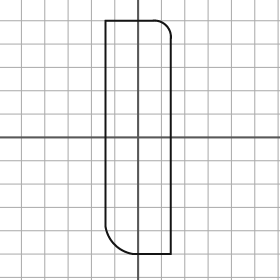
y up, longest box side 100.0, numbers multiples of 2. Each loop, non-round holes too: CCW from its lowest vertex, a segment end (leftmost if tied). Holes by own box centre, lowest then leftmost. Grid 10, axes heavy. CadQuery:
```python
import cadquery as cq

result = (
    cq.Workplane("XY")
    .moveTo(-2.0, -50.0)
    .lineTo(14.0, -50.0)
    .lineTo(14.0, 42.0)
    .threePointArc((12.0, 48.0), (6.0, 50.0))
    .lineTo(-14.0, 50.0)
    .lineTo(-14.0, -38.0)
    .threePointArc((-10.0, -46.0), (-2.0, -50.0))
    .close()
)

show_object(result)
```